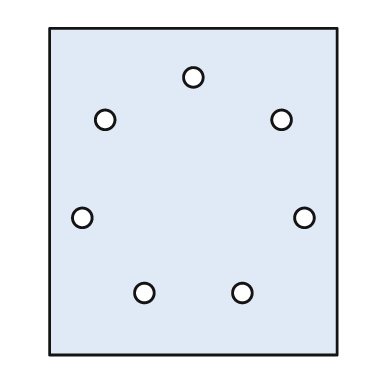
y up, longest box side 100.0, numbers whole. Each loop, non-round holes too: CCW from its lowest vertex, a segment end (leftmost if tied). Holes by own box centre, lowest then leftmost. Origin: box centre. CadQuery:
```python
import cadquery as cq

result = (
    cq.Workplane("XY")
    .moveTo(-44.0, -50.0)
    .lineTo(44.0, -50.0)
    .lineTo(44.0, 50.0)
    .lineTo(-44.0, 50.0)
    .close()
    .moveTo(-15.0, -31.0)
    .circle(3.0)
    .moveTo(15.0, -31.0)
    .circle(3.0)
    .moveTo(-34.0, -8.0)
    .circle(3.0)
    .moveTo(34.0, -8.0)
    .circle(3.0)
    .moveTo(-27.0, 22.0)
    .circle(3.0)
    .moveTo(27.0, 22.0)
    .circle(3.0)
    .moveTo(0.0, 35.0)
    .circle(3.0)
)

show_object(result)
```